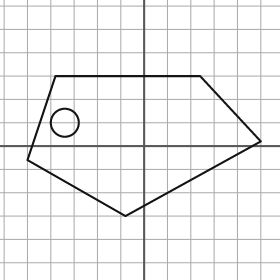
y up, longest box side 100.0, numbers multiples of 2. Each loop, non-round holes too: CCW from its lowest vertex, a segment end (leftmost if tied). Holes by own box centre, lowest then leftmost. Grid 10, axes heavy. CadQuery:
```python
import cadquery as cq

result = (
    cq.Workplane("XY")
    .moveTo(-8.0, -30.0)
    .lineTo(50.0, 2.0)
    .lineTo(24.0, 30.0)
    .lineTo(-38.0, 30.0)
    .lineTo(-50.0, -6.0)
    .close()
    .moveTo(-34.0, 10.0)
    .circle(6.0)
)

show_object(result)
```